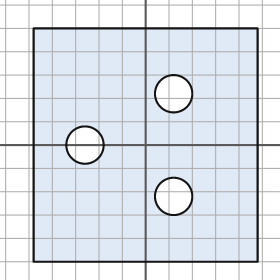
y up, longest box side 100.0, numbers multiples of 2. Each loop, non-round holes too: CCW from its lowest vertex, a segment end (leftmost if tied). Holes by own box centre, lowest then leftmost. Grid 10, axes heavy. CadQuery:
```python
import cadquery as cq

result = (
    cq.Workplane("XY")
    .moveTo(-48.0, -50.0)
    .lineTo(48.0, -50.0)
    .lineTo(48.0, 50.0)
    .lineTo(-48.0, 50.0)
    .close()
    .moveTo(12.0, -22.0)
    .circle(8.0)
    .moveTo(-26.0, 0.0)
    .circle(8.0)
    .moveTo(12.0, 22.0)
    .circle(8.0)
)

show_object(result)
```